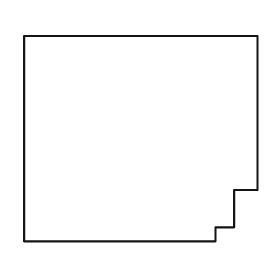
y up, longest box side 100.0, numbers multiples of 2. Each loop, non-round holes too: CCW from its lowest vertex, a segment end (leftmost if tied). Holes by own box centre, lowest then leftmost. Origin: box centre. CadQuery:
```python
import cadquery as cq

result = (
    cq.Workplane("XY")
    .moveTo(-50.0, -44.0)
    .lineTo(32.0, -44.0)
    .lineTo(32.0, -38.0)
    .lineTo(40.0, -38.0)
    .lineTo(40.0, -22.0)
    .lineTo(50.0, -22.0)
    .lineTo(50.0, 44.0)
    .lineTo(-50.0, 44.0)
    .close()
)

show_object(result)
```